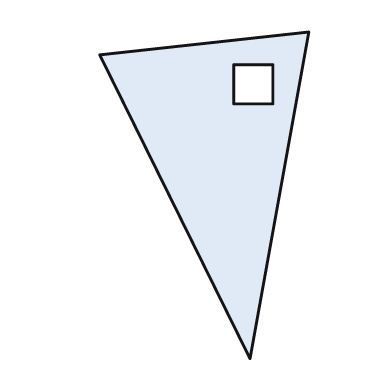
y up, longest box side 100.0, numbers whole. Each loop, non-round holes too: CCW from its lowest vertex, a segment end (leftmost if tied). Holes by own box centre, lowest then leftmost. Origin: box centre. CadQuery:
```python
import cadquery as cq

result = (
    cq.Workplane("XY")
    .moveTo(14.0, -50.0)
    .lineTo(32.0, 50.0)
    .lineTo(-32.0, 43.0)
    .close()
    .moveTo(9.0, 28.0)
    .lineTo(21.0, 28.0)
    .lineTo(21.0, 40.0)
    .lineTo(9.0, 40.0)
    .close()
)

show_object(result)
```